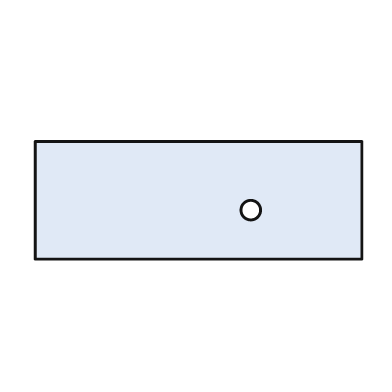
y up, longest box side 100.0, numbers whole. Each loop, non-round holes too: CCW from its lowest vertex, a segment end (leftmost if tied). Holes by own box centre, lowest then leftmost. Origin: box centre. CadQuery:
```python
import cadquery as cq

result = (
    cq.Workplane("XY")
    .moveTo(-50.0, -18.0)
    .lineTo(50.0, -18.0)
    .lineTo(50.0, 18.0)
    .lineTo(-50.0, 18.0)
    .close()
    .moveTo(16.0, -3.0)
    .circle(3.0)
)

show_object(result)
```